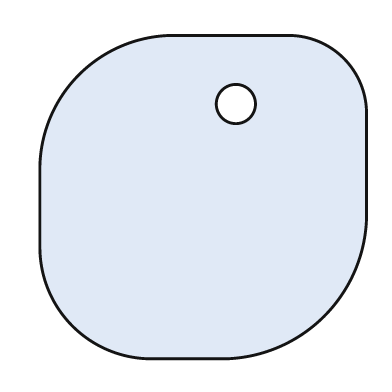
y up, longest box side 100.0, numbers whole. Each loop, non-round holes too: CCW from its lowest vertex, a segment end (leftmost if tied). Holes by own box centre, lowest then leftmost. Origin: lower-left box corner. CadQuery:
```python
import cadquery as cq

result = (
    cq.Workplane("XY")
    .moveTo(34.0, 0.0)
    .lineTo(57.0, 0.0)
    .threePointArc((87.0, 13.0), (100.0, 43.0))
    .lineTo(100.0, 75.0)
    .threePointArc((93.0, 92.0), (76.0, 99.0))
    .lineTo(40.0, 99.0)
    .threePointArc((12.0, 87.0), (0.0, 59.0))
    .lineTo(0.0, 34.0)
    .threePointArc((10.0, 10.0), (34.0, 0.0))
    .close()
    .moveTo(60.0, 78.0)
    .circle(6.0)
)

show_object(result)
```